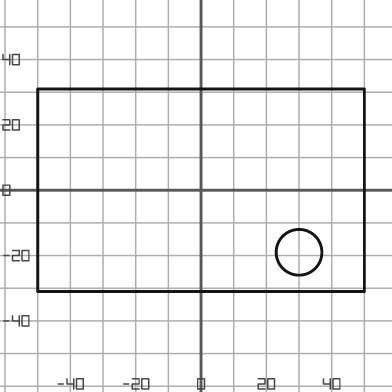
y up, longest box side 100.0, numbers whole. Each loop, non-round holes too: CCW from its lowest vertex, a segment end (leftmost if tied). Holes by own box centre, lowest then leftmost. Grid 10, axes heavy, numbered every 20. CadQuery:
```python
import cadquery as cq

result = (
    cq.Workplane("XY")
    .moveTo(-50.0, -31.0)
    .lineTo(50.0, -31.0)
    .lineTo(50.0, 31.0)
    .lineTo(-50.0, 31.0)
    .close()
    .moveTo(30.0, -19.0)
    .circle(7.0)
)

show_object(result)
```